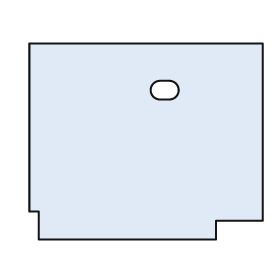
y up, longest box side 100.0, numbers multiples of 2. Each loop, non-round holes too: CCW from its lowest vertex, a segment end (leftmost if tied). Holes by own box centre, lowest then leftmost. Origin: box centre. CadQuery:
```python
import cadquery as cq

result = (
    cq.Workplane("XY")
    .moveTo(-46.0, -42.0)
    .lineTo(30.0, -42.0)
    .lineTo(30.0, -34.0)
    .lineTo(50.0, -34.0)
    .lineTo(50.0, 42.0)
    .lineTo(-50.0, 42.0)
    .lineTo(-50.0, -30.0)
    .lineTo(-46.0, -30.0)
    .close()
    .moveTo(6.0, 18.0)
    .lineTo(10.0, 18.0)
    .threePointArc((14.0, 22.0), (10.0, 26.0))
    .lineTo(6.0, 26.0)
    .threePointArc((2.0, 22.0), (6.0, 18.0))
    .close()
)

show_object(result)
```